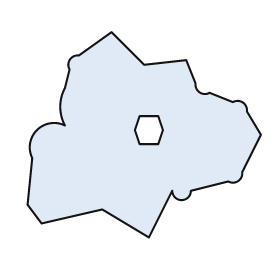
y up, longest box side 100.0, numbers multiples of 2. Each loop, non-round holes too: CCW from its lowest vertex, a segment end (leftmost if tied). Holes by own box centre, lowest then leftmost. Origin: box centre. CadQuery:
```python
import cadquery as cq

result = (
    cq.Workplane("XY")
    .moveTo(2.0, -44.0)
    .lineTo(12.0, -24.0)
    .threePointArc((16.0, -28.0), (20.0, -24.0))
    .lineTo(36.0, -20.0)
    .threePointArc((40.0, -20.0), (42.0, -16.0))
    .lineTo(50.0, 0.0)
    .lineTo(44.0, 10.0)
    .threePointArc((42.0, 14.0), (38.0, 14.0))
    .lineTo(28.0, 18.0)
    .threePointArc((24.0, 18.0), (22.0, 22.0))
    .lineTo(18.0, 32.0)
    .lineTo(0.0, 30.0)
    .lineTo(-14.0, 44.0)
    .lineTo(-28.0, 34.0)
    .threePointArc((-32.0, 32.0), (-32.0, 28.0))
    .lineTo(-34.0, 20.0)
    .threePointArc((-36.0, 12.0), (-34.0, 4.0))
    .threePointArc((-46.0, 2.0), (-48.0, -10.0))
    .lineTo(-50.0, -30.0)
    .lineTo(-44.0, -38.0)
    .lineTo(-18.0, -32.0)
    .close()
    .moveTo(-2.0, -4.0)
    .lineTo(6.0, -4.0)
    .lineTo(8.0, 2.0)
    .lineTo(6.0, 8.0)
    .lineTo(-2.0, 8.0)
    .lineTo(-4.0, 2.0)
    .close()
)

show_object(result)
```